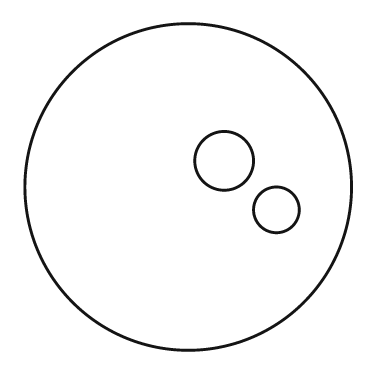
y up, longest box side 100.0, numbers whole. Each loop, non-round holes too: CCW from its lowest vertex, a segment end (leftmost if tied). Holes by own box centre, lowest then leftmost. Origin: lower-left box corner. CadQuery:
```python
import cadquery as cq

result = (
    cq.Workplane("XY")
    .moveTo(50.0, 50.0)
    .circle(50.0)
    .moveTo(77.0, 43.0)
    .circle(7.0)
    .moveTo(61.0, 58.0)
    .circle(9.0)
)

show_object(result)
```